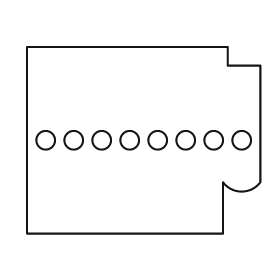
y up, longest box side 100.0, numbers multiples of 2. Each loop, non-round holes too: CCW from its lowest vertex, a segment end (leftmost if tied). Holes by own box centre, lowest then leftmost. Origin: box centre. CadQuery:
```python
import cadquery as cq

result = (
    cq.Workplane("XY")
    .moveTo(-50.0, -40.0)
    .lineTo(34.0, -40.0)
    .lineTo(34.0, -18.0)
    .threePointArc((42.0, -22.0), (50.0, -18.0))
    .lineTo(50.0, 32.0)
    .lineTo(36.0, 32.0)
    .lineTo(36.0, 40.0)
    .lineTo(-50.0, 40.0)
    .close()
    .moveTo(-42.0, 0.0)
    .circle(4.0)
    .moveTo(-30.0, 0.0)
    .circle(4.0)
    .moveTo(-18.0, 0.0)
    .circle(4.0)
    .moveTo(-6.0, 0.0)
    .circle(4.0)
    .moveTo(6.0, 0.0)
    .circle(4.0)
    .moveTo(18.0, 0.0)
    .circle(4.0)
    .moveTo(30.0, 0.0)
    .circle(4.0)
    .moveTo(42.0, 0.0)
    .circle(4.0)
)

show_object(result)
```